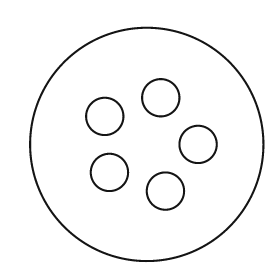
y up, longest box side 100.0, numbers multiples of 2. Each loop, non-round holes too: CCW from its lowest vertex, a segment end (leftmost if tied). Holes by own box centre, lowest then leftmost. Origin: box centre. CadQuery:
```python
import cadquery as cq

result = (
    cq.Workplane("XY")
    .moveTo(0.0, 0.0)
    .circle(50.0)
    .moveTo(8.0, -20.0)
    .circle(8.0)
    .moveTo(-16.0, -12.0)
    .circle(8.0)
    .moveTo(22.0, 0.0)
    .circle(8.0)
    .moveTo(-18.0, 12.0)
    .circle(8.0)
    .moveTo(6.0, 20.0)
    .circle(8.0)
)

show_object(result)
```